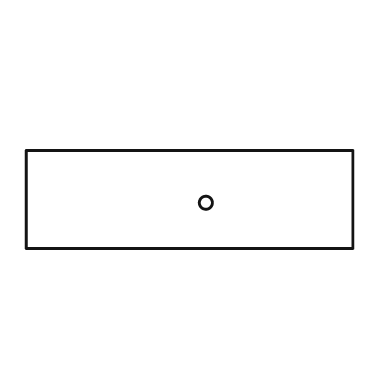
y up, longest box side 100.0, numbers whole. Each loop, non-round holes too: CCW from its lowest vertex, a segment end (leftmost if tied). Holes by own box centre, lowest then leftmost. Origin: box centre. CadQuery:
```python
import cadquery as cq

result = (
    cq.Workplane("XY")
    .moveTo(-50.0, -15.0)
    .lineTo(50.0, -15.0)
    .lineTo(50.0, 15.0)
    .lineTo(-50.0, 15.0)
    .close()
    .moveTo(5.0, -1.0)
    .circle(2.0)
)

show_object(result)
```